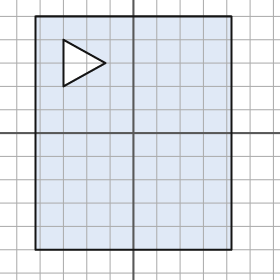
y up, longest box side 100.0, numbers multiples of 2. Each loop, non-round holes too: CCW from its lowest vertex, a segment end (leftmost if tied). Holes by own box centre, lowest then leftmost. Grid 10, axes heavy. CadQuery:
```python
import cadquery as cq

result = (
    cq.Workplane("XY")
    .moveTo(-42.0, -50.0)
    .lineTo(42.0, -50.0)
    .lineTo(42.0, 50.0)
    .lineTo(-42.0, 50.0)
    .close()
    .moveTo(-30.0, 20.0)
    .lineTo(-12.0, 30.0)
    .lineTo(-30.0, 40.0)
    .close()
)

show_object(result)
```